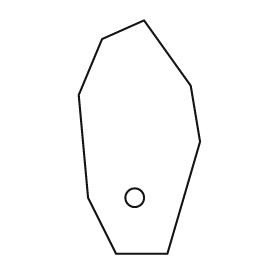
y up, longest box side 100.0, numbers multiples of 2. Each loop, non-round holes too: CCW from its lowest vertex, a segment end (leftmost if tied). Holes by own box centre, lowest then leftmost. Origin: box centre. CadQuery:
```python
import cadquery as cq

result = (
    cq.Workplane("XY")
    .moveTo(-10.0, -50.0)
    .lineTo(12.0, -50.0)
    .lineTo(26.0, -2.0)
    .lineTo(22.0, 22.0)
    .lineTo(2.0, 50.0)
    .lineTo(-16.0, 42.0)
    .lineTo(-26.0, 18.0)
    .lineTo(-22.0, -26.0)
    .close()
    .moveTo(-2.0, -26.0)
    .circle(4.0)
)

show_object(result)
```